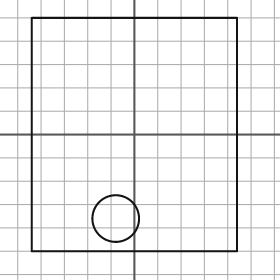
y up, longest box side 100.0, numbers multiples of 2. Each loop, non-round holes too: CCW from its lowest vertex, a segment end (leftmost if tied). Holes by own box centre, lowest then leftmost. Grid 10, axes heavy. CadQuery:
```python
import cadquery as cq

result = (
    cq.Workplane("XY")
    .moveTo(-44.0, -50.0)
    .lineTo(44.0, -50.0)
    .lineTo(44.0, 50.0)
    .lineTo(-44.0, 50.0)
    .close()
    .moveTo(-8.0, -36.0)
    .circle(10.0)
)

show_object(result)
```